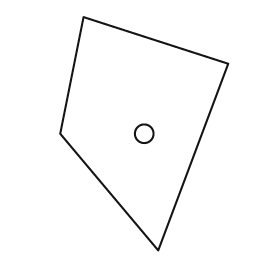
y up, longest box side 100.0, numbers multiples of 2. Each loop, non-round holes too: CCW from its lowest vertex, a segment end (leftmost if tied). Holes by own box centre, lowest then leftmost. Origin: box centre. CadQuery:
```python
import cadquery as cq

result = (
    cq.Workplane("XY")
    .moveTo(6.0, -50.0)
    .lineTo(36.0, 30.0)
    .lineTo(-26.0, 50.0)
    .lineTo(-36.0, 0.0)
    .close()
    .moveTo(0.0, 0.0)
    .circle(4.0)
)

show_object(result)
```